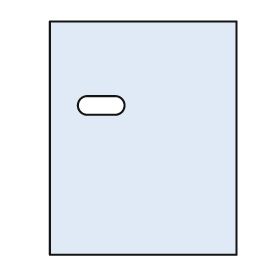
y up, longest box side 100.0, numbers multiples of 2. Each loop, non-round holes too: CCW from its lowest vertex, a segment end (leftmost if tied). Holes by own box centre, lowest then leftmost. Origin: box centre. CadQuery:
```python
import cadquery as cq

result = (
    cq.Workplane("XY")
    .moveTo(-40.0, -50.0)
    .lineTo(40.0, -50.0)
    .lineTo(40.0, 50.0)
    .lineTo(-40.0, 50.0)
    .close()
    .moveTo(-24.0, 10.0)
    .lineTo(-12.0, 10.0)
    .threePointArc((-8.0, 14.0), (-12.0, 18.0))
    .lineTo(-24.0, 18.0)
    .threePointArc((-28.0, 14.0), (-24.0, 10.0))
    .close()
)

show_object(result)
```